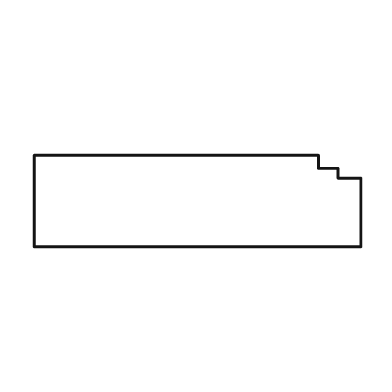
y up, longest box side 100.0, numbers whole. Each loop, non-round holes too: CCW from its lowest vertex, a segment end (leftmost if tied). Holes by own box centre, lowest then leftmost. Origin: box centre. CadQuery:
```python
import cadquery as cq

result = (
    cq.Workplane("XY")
    .moveTo(-50.0, -14.0)
    .lineTo(50.0, -14.0)
    .lineTo(50.0, 7.0)
    .lineTo(43.0, 7.0)
    .lineTo(43.0, 10.0)
    .lineTo(37.0, 10.0)
    .lineTo(37.0, 14.0)
    .lineTo(-50.0, 14.0)
    .close()
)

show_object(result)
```